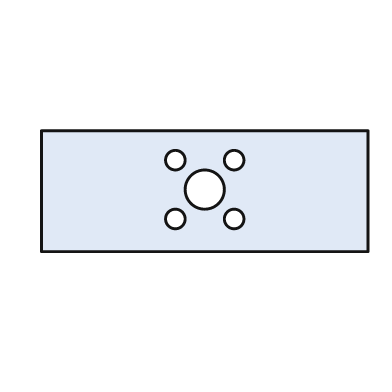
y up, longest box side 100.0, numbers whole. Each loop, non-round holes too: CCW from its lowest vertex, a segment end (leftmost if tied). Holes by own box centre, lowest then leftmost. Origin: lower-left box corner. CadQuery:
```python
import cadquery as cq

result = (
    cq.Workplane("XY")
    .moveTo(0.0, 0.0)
    .lineTo(100.0, 0.0)
    .lineTo(100.0, 37.0)
    .lineTo(0.0, 37.0)
    .close()
    .moveTo(41.0, 10.0)
    .circle(3.0)
    .moveTo(59.0, 10.0)
    .circle(3.0)
    .moveTo(50.0, 19.0)
    .circle(6.0)
    .moveTo(41.0, 28.0)
    .circle(3.0)
    .moveTo(59.0, 28.0)
    .circle(3.0)
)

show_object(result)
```